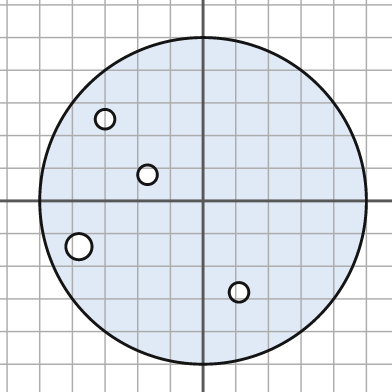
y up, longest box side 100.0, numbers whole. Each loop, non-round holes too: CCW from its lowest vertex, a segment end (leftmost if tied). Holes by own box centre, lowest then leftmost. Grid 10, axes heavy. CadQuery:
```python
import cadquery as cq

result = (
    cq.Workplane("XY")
    .moveTo(0.0, 0.0)
    .circle(50.0)
    .moveTo(11.0, -28.0)
    .circle(3.0)
    .moveTo(-38.0, -14.0)
    .circle(4.0)
    .moveTo(-17.0, 8.0)
    .circle(3.0)
    .moveTo(-30.0, 25.0)
    .circle(3.0)
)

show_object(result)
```